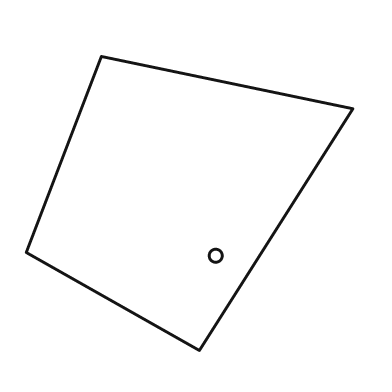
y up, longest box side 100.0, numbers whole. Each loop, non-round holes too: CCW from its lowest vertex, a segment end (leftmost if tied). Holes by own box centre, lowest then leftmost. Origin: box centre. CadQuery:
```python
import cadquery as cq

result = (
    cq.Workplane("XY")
    .moveTo(3.0, -45.0)
    .lineTo(50.0, 29.0)
    .lineTo(-27.0, 45.0)
    .lineTo(-50.0, -15.0)
    .close()
    .moveTo(8.0, -16.0)
    .circle(2.0)
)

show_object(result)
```